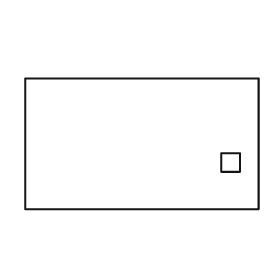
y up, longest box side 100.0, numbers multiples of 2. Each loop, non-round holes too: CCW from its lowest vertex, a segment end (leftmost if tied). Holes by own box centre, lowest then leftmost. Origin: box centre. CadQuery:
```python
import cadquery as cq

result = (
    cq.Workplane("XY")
    .moveTo(-50.0, -28.0)
    .lineTo(50.0, -28.0)
    .lineTo(50.0, 28.0)
    .lineTo(-50.0, 28.0)
    .close()
    .moveTo(34.0, -12.0)
    .lineTo(42.0, -12.0)
    .lineTo(42.0, -4.0)
    .lineTo(34.0, -4.0)
    .close()
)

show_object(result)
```